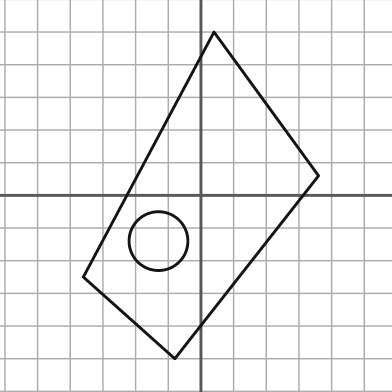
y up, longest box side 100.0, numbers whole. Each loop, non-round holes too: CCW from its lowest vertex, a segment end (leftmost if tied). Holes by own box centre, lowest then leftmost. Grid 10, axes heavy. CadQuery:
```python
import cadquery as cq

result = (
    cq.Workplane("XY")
    .moveTo(-8.0, -50.0)
    .lineTo(36.0, 6.0)
    .lineTo(4.0, 50.0)
    .lineTo(-36.0, -25.0)
    .close()
    .moveTo(-13.0, -14.0)
    .circle(9.0)
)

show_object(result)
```